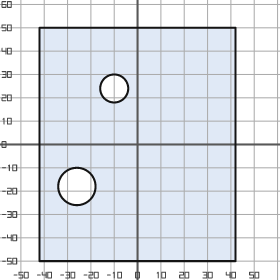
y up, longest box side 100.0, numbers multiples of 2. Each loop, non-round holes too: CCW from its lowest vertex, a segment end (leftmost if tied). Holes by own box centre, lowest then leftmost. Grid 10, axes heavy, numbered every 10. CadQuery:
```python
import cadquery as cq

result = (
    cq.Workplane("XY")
    .moveTo(-42.0, -50.0)
    .lineTo(42.0, -50.0)
    .lineTo(42.0, 50.0)
    .lineTo(-42.0, 50.0)
    .close()
    .moveTo(-26.0, -18.0)
    .circle(8.0)
    .moveTo(-10.0, 24.0)
    .circle(6.0)
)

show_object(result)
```